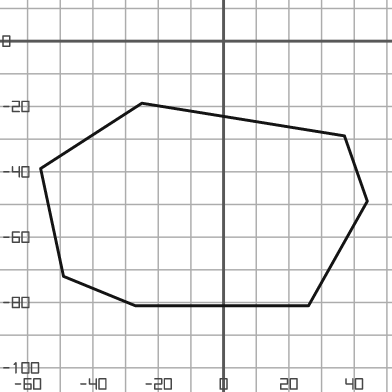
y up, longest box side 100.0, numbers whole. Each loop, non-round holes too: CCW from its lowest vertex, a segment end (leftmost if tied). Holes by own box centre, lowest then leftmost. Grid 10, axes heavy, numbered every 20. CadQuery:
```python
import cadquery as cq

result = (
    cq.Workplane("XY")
    .moveTo(-27.0, -81.0)
    .lineTo(26.0, -81.0)
    .lineTo(44.0, -49.0)
    .lineTo(37.0, -29.0)
    .lineTo(-25.0, -19.0)
    .lineTo(-56.0, -39.0)
    .lineTo(-49.0, -72.0)
    .close()
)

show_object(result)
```